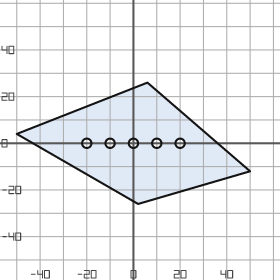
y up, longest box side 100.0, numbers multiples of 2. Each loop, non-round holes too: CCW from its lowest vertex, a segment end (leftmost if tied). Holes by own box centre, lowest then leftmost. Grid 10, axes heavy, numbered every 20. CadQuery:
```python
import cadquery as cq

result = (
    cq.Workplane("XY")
    .moveTo(2.0, -26.0)
    .lineTo(50.0, -12.0)
    .lineTo(6.0, 26.0)
    .lineTo(-50.0, 4.0)
    .close()
    .moveTo(-20.0, 0.0)
    .circle(2.0)
    .moveTo(-10.0, 0.0)
    .circle(2.0)
    .moveTo(0.0, 0.0)
    .circle(2.0)
    .moveTo(10.0, 0.0)
    .circle(2.0)
    .moveTo(20.0, 0.0)
    .circle(2.0)
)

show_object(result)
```